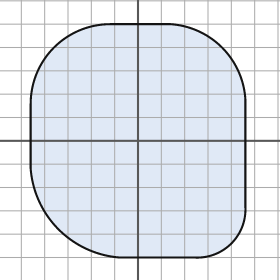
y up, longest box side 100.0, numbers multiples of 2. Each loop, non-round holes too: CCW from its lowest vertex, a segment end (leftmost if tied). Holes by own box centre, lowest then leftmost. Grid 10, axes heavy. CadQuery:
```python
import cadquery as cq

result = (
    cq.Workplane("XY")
    .moveTo(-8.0, -50.0)
    .lineTo(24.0, -50.0)
    .threePointArc((40.0, -44.0), (46.0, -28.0))
    .lineTo(46.0, 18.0)
    .threePointArc((36.0, 40.0), (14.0, 50.0))
    .lineTo(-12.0, 50.0)
    .threePointArc((-36.0, 40.0), (-46.0, 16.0))
    .lineTo(-46.0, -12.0)
    .threePointArc((-34.0, -38.0), (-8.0, -50.0))
    .close()
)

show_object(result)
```